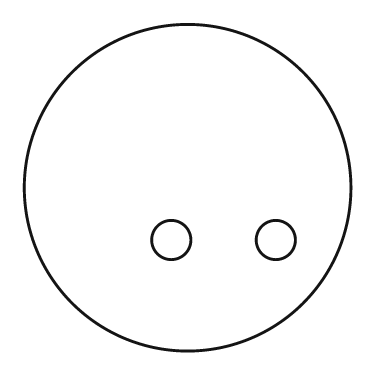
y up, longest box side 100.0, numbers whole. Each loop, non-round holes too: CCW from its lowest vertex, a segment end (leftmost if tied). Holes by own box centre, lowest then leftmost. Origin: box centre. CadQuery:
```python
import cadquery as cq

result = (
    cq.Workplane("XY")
    .moveTo(0.0, 0.0)
    .circle(50.0)
    .moveTo(-5.0, -16.0)
    .circle(6.0)
    .moveTo(27.0, -16.0)
    .circle(6.0)
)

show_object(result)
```